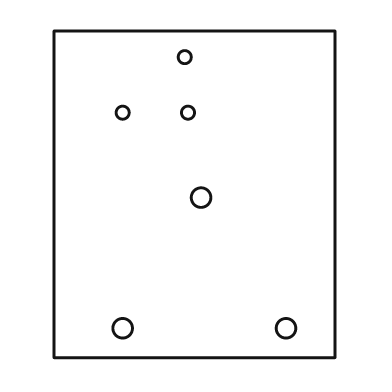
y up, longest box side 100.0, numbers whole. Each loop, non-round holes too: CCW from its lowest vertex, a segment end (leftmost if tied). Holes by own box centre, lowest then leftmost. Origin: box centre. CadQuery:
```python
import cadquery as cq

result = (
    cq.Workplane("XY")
    .moveTo(-43.0, -50.0)
    .lineTo(43.0, -50.0)
    .lineTo(43.0, 50.0)
    .lineTo(-43.0, 50.0)
    .close()
    .moveTo(-22.0, -41.0)
    .circle(3.0)
    .moveTo(28.0, -41.0)
    .circle(3.0)
    .moveTo(2.0, -1.0)
    .circle(3.0)
    .moveTo(-22.0, 25.0)
    .circle(2.0)
    .moveTo(-2.0, 25.0)
    .circle(2.0)
    .moveTo(-3.0, 42.0)
    .circle(2.0)
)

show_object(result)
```